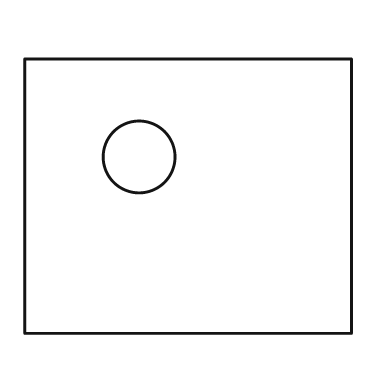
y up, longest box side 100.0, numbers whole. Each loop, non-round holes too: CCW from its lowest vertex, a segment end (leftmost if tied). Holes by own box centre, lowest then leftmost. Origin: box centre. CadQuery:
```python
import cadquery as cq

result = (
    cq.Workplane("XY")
    .moveTo(-50.0, -42.0)
    .lineTo(50.0, -42.0)
    .lineTo(50.0, 42.0)
    .lineTo(-50.0, 42.0)
    .close()
    .moveTo(-15.0, 12.0)
    .circle(11.0)
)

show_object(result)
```